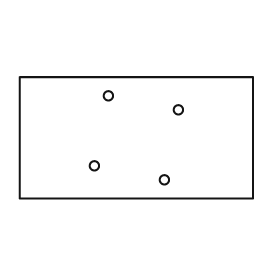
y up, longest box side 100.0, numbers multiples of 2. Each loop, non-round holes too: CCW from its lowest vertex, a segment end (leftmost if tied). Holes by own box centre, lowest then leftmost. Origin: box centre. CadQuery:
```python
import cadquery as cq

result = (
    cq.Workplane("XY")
    .moveTo(-50.0, -26.0)
    .lineTo(50.0, -26.0)
    .lineTo(50.0, 26.0)
    .lineTo(-50.0, 26.0)
    .close()
    .moveTo(12.0, -18.0)
    .circle(2.0)
    .moveTo(-18.0, -12.0)
    .circle(2.0)
    .moveTo(18.0, 12.0)
    .circle(2.0)
    .moveTo(-12.0, 18.0)
    .circle(2.0)
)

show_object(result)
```